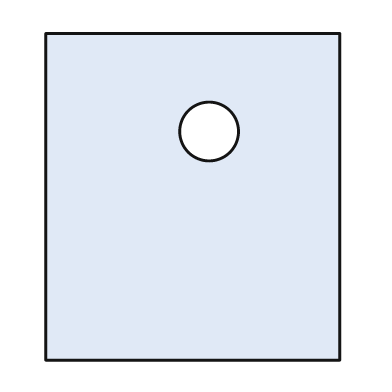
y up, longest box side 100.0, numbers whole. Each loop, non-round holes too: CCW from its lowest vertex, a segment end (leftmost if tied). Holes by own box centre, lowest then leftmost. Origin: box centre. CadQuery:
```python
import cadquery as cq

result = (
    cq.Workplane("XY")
    .moveTo(-45.0, -50.0)
    .lineTo(45.0, -50.0)
    .lineTo(45.0, 50.0)
    .lineTo(-45.0, 50.0)
    .close()
    .moveTo(5.0, 20.0)
    .circle(9.0)
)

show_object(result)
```